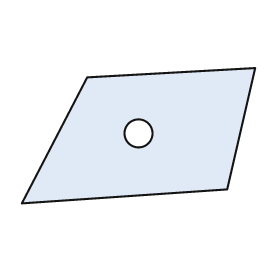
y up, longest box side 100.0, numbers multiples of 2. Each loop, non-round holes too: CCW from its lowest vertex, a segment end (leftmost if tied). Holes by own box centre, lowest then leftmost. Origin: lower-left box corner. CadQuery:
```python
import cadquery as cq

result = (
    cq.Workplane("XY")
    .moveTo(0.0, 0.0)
    .lineTo(88.0, 6.0)
    .lineTo(100.0, 58.0)
    .lineTo(28.0, 54.0)
    .close()
    .moveTo(50.0, 30.0)
    .circle(6.0)
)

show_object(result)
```